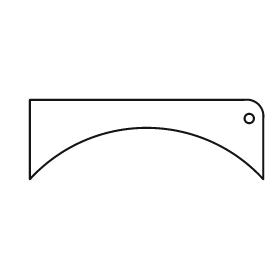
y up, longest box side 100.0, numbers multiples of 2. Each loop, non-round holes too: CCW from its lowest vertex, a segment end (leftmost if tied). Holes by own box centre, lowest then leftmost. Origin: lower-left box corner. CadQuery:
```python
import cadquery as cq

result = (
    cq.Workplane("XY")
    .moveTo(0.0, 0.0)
    .threePointArc((50.0, 22.0), (100.0, 0.0))
    .lineTo(100.0, 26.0)
    .threePointArc((98.0, 32.0), (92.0, 34.0))
    .lineTo(0.0, 34.0)
    .close()
    .moveTo(94.0, 26.0)
    .circle(2.0)
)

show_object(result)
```